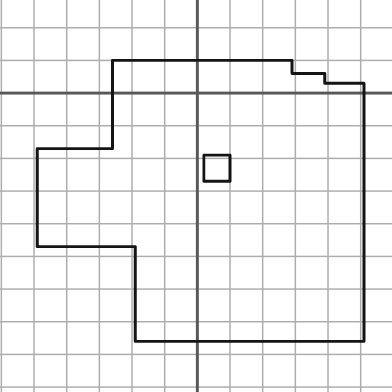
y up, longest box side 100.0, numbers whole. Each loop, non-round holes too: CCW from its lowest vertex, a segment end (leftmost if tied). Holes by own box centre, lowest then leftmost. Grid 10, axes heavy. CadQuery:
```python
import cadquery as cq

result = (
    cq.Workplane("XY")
    .moveTo(-19.0, -76.0)
    .lineTo(51.0, -76.0)
    .lineTo(51.0, 3.0)
    .lineTo(39.0, 3.0)
    .lineTo(39.0, 6.0)
    .lineTo(29.0, 6.0)
    .lineTo(29.0, 10.0)
    .lineTo(-26.0, 10.0)
    .lineTo(-26.0, -17.0)
    .lineTo(-49.0, -17.0)
    .lineTo(-49.0, -47.0)
    .lineTo(-19.0, -47.0)
    .close()
    .moveTo(2.0, -27.0)
    .lineTo(10.0, -27.0)
    .lineTo(10.0, -19.0)
    .lineTo(2.0, -19.0)
    .close()
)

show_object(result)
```